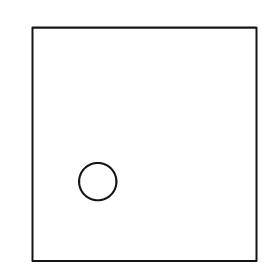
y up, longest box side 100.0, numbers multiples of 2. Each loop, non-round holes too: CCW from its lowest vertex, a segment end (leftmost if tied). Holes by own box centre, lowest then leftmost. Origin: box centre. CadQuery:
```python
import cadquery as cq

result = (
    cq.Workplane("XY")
    .moveTo(-48.0, -50.0)
    .lineTo(48.0, -50.0)
    .lineTo(48.0, 50.0)
    .lineTo(-48.0, 50.0)
    .close()
    .moveTo(-20.0, -16.0)
    .circle(8.0)
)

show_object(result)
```